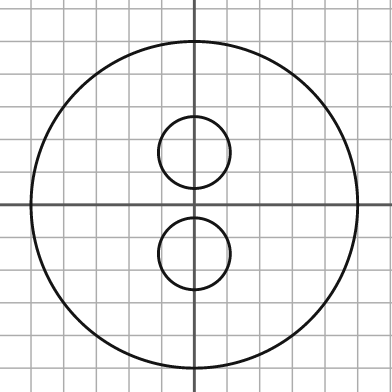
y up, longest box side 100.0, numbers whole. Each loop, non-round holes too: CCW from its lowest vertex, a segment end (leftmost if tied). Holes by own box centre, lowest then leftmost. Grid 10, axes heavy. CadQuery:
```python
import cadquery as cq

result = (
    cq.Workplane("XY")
    .moveTo(0.0, 0.0)
    .circle(50.0)
    .moveTo(0.0, -15.0)
    .circle(11.0)
    .moveTo(0.0, 16.0)
    .circle(11.0)
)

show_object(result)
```